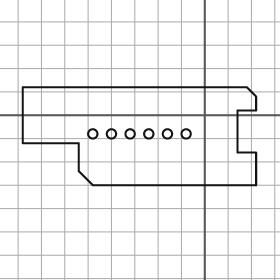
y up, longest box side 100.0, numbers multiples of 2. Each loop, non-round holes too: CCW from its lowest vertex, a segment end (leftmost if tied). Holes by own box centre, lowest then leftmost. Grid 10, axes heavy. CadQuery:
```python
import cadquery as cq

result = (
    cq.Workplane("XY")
    .moveTo(-48.0, -30.0)
    .lineTo(22.0, -30.0)
    .lineTo(22.0, -16.0)
    .lineTo(14.0, -16.0)
    .lineTo(14.0, 2.0)
    .lineTo(22.0, 2.0)
    .lineTo(22.0, 8.0)
    .lineTo(18.0, 12.0)
    .lineTo(-78.0, 12.0)
    .lineTo(-78.0, -12.0)
    .lineTo(-54.0, -12.0)
    .lineTo(-54.0, -24.0)
    .close()
    .moveTo(-48.0, -8.0)
    .circle(2.0)
    .moveTo(-40.0, -8.0)
    .circle(2.0)
    .moveTo(-32.0, -8.0)
    .circle(2.0)
    .moveTo(-24.0, -8.0)
    .circle(2.0)
    .moveTo(-16.0, -8.0)
    .circle(2.0)
    .moveTo(-8.0, -8.0)
    .circle(2.0)
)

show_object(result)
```